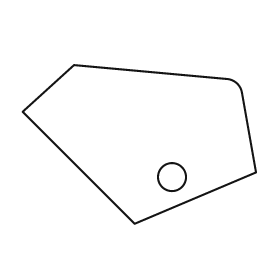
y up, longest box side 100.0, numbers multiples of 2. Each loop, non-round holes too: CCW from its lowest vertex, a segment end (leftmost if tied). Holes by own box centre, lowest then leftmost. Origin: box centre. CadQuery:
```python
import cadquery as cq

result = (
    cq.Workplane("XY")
    .moveTo(-2.0, -34.0)
    .lineTo(50.0, -12.0)
    .lineTo(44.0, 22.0)
    .threePointArc((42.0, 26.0), (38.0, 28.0))
    .lineTo(-28.0, 34.0)
    .lineTo(-50.0, 14.0)
    .close()
    .moveTo(14.0, -14.0)
    .circle(6.0)
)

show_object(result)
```